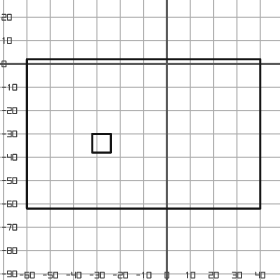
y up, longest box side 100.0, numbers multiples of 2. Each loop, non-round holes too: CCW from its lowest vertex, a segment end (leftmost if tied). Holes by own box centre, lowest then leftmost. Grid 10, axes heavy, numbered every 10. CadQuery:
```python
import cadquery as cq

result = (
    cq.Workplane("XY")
    .moveTo(-60.0, -62.0)
    .lineTo(40.0, -62.0)
    .lineTo(40.0, 2.0)
    .lineTo(-60.0, 2.0)
    .close()
    .moveTo(-32.0, -38.0)
    .lineTo(-24.0, -38.0)
    .lineTo(-24.0, -30.0)
    .lineTo(-32.0, -30.0)
    .close()
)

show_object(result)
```